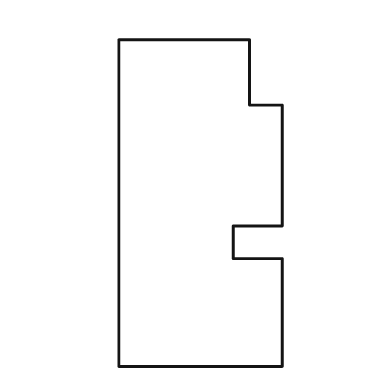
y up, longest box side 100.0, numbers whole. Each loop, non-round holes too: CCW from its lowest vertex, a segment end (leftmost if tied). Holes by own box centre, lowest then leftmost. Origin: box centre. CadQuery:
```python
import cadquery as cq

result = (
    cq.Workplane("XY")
    .moveTo(-25.0, -50.0)
    .lineTo(25.0, -50.0)
    .lineTo(25.0, -17.0)
    .lineTo(10.0, -17.0)
    .lineTo(10.0, -7.0)
    .lineTo(25.0, -7.0)
    .lineTo(25.0, 30.0)
    .lineTo(15.0, 30.0)
    .lineTo(15.0, 50.0)
    .lineTo(-25.0, 50.0)
    .close()
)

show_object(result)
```